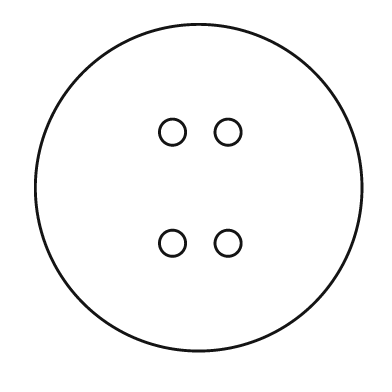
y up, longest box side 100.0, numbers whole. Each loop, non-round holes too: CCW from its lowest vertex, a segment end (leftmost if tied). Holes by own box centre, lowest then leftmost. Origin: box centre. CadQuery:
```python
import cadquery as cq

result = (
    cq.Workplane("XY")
    .moveTo(0.0, 0.0)
    .circle(50.0)
    .moveTo(-8.0, -17.0)
    .circle(4.0)
    .moveTo(9.0, -17.0)
    .circle(4.0)
    .moveTo(-8.0, 17.0)
    .circle(4.0)
    .moveTo(9.0, 17.0)
    .circle(4.0)
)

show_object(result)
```